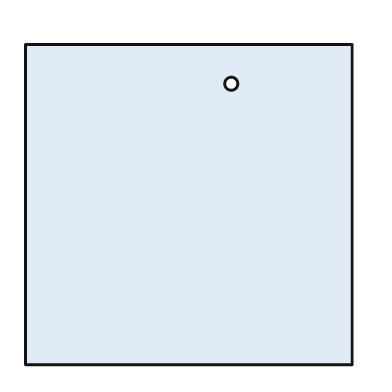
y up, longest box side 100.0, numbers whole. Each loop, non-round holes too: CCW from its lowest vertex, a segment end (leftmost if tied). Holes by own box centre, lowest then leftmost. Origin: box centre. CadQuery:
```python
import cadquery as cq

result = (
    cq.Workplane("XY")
    .moveTo(-50.0, -49.0)
    .lineTo(50.0, -49.0)
    .lineTo(50.0, 49.0)
    .lineTo(-50.0, 49.0)
    .close()
    .moveTo(13.0, 37.0)
    .circle(2.0)
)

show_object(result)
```